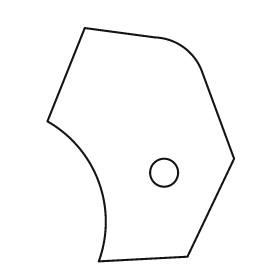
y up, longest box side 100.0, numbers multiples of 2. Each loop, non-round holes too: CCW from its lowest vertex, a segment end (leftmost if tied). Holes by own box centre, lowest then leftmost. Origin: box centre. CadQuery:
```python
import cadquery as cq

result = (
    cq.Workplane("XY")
    .moveTo(-18.0, -50.0)
    .lineTo(20.0, -48.0)
    .lineTo(40.0, -6.0)
    .lineTo(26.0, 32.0)
    .threePointArc((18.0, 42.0), (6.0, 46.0))
    .lineTo(-24.0, 50.0)
    .lineTo(-40.0, 10.0)
    .threePointArc((-18.0, -16.0), (-18.0, -50.0))
    .close()
    .moveTo(10.0, -12.0)
    .circle(6.0)
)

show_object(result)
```